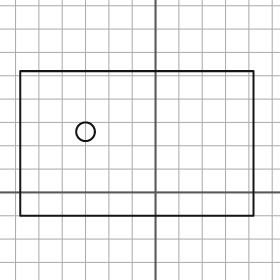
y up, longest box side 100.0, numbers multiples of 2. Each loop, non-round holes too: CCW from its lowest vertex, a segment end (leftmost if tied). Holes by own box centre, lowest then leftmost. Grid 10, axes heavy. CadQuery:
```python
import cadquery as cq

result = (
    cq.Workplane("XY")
    .moveTo(-58.0, -10.0)
    .lineTo(42.0, -10.0)
    .lineTo(42.0, 52.0)
    .lineTo(-58.0, 52.0)
    .close()
    .moveTo(-30.0, 26.0)
    .circle(4.0)
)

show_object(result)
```